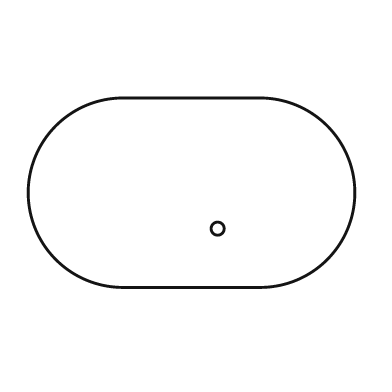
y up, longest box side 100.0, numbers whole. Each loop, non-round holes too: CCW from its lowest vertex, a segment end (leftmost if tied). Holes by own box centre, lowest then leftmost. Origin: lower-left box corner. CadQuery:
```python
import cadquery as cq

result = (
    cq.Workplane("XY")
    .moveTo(29.0, 0.0)
    .lineTo(71.0, 0.0)
    .threePointArc((100.0, 29.0), (71.0, 58.0))
    .lineTo(29.0, 58.0)
    .threePointArc((0.0, 29.0), (29.0, 0.0))
    .close()
    .moveTo(58.0, 18.0)
    .circle(2.0)
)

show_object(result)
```